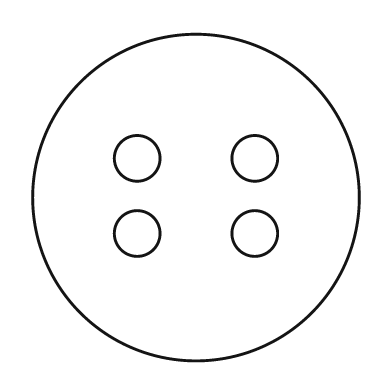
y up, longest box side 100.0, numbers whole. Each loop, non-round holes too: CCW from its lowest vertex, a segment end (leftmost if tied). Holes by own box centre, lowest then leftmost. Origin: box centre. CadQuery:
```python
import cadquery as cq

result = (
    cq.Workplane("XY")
    .moveTo(0.0, 0.0)
    .circle(50.0)
    .moveTo(-18.0, -11.0)
    .circle(7.0)
    .moveTo(18.0, -11.0)
    .circle(7.0)
    .moveTo(-18.0, 12.0)
    .circle(7.0)
    .moveTo(18.0, 12.0)
    .circle(7.0)
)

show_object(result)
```